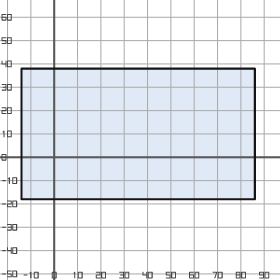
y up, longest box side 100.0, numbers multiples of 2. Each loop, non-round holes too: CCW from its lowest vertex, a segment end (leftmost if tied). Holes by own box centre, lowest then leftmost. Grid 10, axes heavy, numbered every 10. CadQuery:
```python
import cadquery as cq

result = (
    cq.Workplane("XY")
    .moveTo(-14.0, -18.0)
    .lineTo(86.0, -18.0)
    .lineTo(86.0, 38.0)
    .lineTo(-14.0, 38.0)
    .close()
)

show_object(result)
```